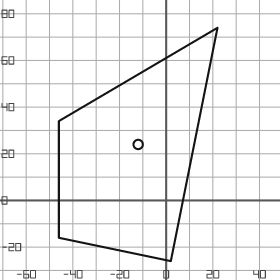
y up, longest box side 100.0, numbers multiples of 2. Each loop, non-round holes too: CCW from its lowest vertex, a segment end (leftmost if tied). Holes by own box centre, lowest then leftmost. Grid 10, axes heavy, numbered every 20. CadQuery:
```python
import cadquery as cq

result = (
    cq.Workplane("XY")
    .moveTo(2.0, -26.0)
    .lineTo(22.0, 74.0)
    .lineTo(-46.0, 34.0)
    .lineTo(-46.0, -16.0)
    .close()
    .moveTo(-12.0, 24.0)
    .circle(2.0)
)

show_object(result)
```